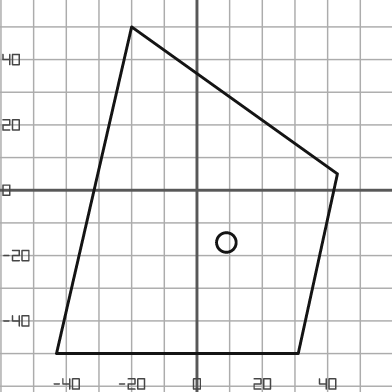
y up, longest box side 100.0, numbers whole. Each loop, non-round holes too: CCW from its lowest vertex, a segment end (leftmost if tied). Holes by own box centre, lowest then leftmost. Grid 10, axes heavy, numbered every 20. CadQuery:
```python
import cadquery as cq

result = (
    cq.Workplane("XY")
    .moveTo(-43.0, -50.0)
    .lineTo(31.0, -50.0)
    .lineTo(43.0, 5.0)
    .lineTo(-20.0, 50.0)
    .close()
    .moveTo(9.0, -16.0)
    .circle(3.0)
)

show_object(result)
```